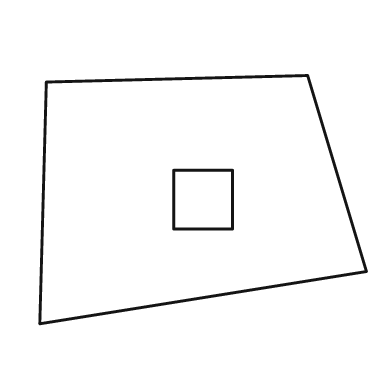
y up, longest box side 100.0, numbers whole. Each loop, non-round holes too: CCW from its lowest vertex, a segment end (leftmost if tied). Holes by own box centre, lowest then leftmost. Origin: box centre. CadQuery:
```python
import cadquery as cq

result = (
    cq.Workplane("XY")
    .moveTo(-50.0, -38.0)
    .lineTo(50.0, -22.0)
    .lineTo(32.0, 38.0)
    .lineTo(-48.0, 36.0)
    .close()
    .moveTo(-9.0, -9.0)
    .lineTo(9.0, -9.0)
    .lineTo(9.0, 9.0)
    .lineTo(-9.0, 9.0)
    .close()
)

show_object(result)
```